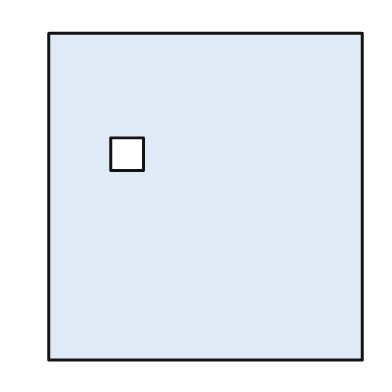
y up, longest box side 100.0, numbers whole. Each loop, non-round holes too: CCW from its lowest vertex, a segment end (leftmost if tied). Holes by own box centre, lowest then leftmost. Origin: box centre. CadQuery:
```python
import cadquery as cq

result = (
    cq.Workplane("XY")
    .moveTo(-48.0, -50.0)
    .lineTo(48.0, -50.0)
    .lineTo(48.0, 50.0)
    .lineTo(-48.0, 50.0)
    .close()
    .moveTo(-29.0, 8.0)
    .lineTo(-19.0, 8.0)
    .lineTo(-19.0, 18.0)
    .lineTo(-29.0, 18.0)
    .close()
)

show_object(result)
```